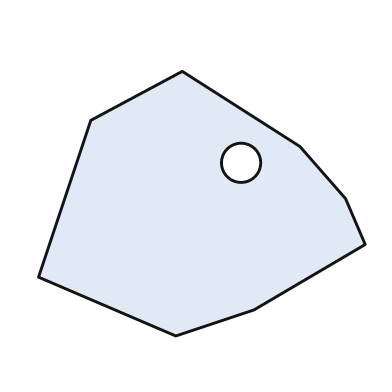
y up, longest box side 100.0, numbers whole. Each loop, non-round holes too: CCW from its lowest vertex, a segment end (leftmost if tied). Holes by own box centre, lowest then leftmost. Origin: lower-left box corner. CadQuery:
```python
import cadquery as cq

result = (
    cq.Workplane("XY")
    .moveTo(42.0, 0.0)
    .lineTo(66.0, 8.0)
    .lineTo(100.0, 28.0)
    .lineTo(94.0, 42.0)
    .lineTo(80.0, 58.0)
    .lineTo(44.0, 81.0)
    .lineTo(16.0, 66.0)
    .lineTo(0.0, 18.0)
    .close()
    .moveTo(62.0, 53.0)
    .circle(6.0)
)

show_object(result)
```